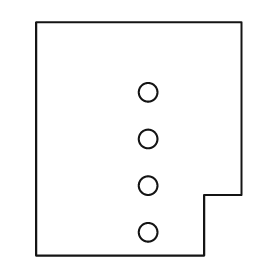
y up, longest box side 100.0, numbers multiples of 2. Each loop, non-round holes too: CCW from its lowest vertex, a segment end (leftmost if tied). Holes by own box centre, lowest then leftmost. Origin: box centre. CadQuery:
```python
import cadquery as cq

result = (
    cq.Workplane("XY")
    .moveTo(-44.0, -50.0)
    .lineTo(28.0, -50.0)
    .lineTo(28.0, -24.0)
    .lineTo(44.0, -24.0)
    .lineTo(44.0, 50.0)
    .lineTo(-44.0, 50.0)
    .close()
    .moveTo(4.0, -40.0)
    .circle(4.0)
    .moveTo(4.0, -20.0)
    .circle(4.0)
    .moveTo(4.0, 0.0)
    .circle(4.0)
    .moveTo(4.0, 20.0)
    .circle(4.0)
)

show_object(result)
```